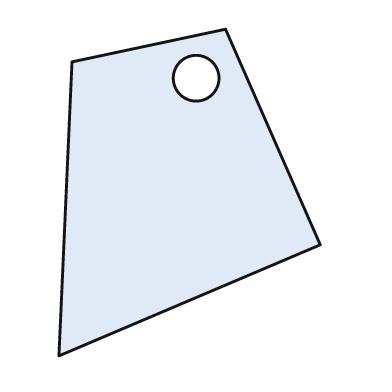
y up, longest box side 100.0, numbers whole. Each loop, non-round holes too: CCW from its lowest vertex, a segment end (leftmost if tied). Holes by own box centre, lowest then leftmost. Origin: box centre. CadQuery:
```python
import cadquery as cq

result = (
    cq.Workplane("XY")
    .moveTo(-40.0, -50.0)
    .lineTo(40.0, -16.0)
    .lineTo(11.0, 50.0)
    .lineTo(-36.0, 40.0)
    .close()
    .moveTo(2.0, 35.0)
    .circle(7.0)
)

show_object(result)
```